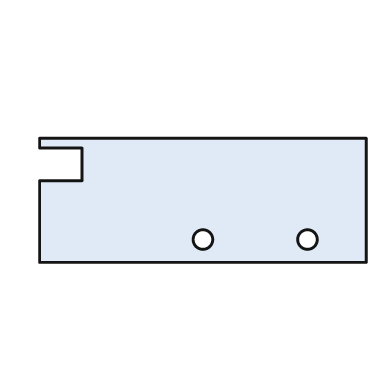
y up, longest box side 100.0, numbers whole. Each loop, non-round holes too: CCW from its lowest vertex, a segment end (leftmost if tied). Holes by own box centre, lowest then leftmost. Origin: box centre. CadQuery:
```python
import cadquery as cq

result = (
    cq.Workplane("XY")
    .moveTo(-50.0, -19.0)
    .lineTo(50.0, -19.0)
    .lineTo(50.0, 19.0)
    .lineTo(-50.0, 19.0)
    .lineTo(-50.0, 16.0)
    .lineTo(-37.0, 16.0)
    .lineTo(-37.0, 6.0)
    .lineTo(-50.0, 6.0)
    .close()
    .moveTo(0.0, -12.0)
    .circle(3.0)
    .moveTo(32.0, -12.0)
    .circle(3.0)
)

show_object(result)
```